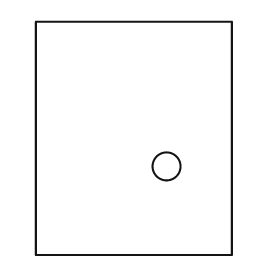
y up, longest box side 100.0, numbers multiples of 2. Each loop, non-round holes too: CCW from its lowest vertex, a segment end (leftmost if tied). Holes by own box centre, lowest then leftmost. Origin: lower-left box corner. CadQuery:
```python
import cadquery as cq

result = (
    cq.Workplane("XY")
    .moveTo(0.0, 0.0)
    .lineTo(84.0, 0.0)
    .lineTo(84.0, 100.0)
    .lineTo(0.0, 100.0)
    .close()
    .moveTo(56.0, 38.0)
    .circle(6.0)
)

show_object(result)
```